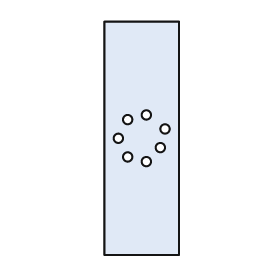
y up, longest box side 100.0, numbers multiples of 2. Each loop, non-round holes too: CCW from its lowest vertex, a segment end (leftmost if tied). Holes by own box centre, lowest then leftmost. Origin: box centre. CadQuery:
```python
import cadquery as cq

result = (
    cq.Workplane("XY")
    .moveTo(-16.0, -50.0)
    .lineTo(16.0, -50.0)
    .lineTo(16.0, 50.0)
    .lineTo(-16.0, 50.0)
    .close()
    .moveTo(2.0, -10.0)
    .circle(2.0)
    .moveTo(-6.0, -8.0)
    .circle(2.0)
    .moveTo(8.0, -4.0)
    .circle(2.0)
    .moveTo(-10.0, 0.0)
    .circle(2.0)
    .moveTo(10.0, 4.0)
    .circle(2.0)
    .moveTo(-6.0, 8.0)
    .circle(2.0)
    .moveTo(2.0, 10.0)
    .circle(2.0)
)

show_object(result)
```